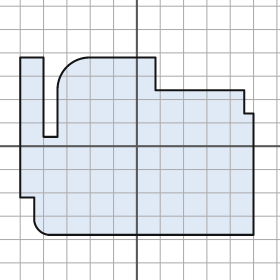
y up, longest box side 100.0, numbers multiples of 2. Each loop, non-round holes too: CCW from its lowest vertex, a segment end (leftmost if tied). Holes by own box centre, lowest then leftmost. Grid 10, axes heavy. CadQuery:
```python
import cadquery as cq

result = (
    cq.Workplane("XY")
    .moveTo(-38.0, -38.0)
    .lineTo(50.0, -38.0)
    .lineTo(50.0, 14.0)
    .lineTo(46.0, 14.0)
    .lineTo(46.0, 24.0)
    .lineTo(8.0, 24.0)
    .lineTo(8.0, 38.0)
    .lineTo(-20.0, 38.0)
    .threePointArc((-30.0, 34.0), (-34.0, 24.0))
    .lineTo(-34.0, 4.0)
    .lineTo(-40.0, 4.0)
    .lineTo(-40.0, 38.0)
    .lineTo(-50.0, 38.0)
    .lineTo(-50.0, -22.0)
    .lineTo(-44.0, -22.0)
    .lineTo(-44.0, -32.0)
    .threePointArc((-42.0, -36.0), (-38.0, -38.0))
    .close()
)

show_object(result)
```